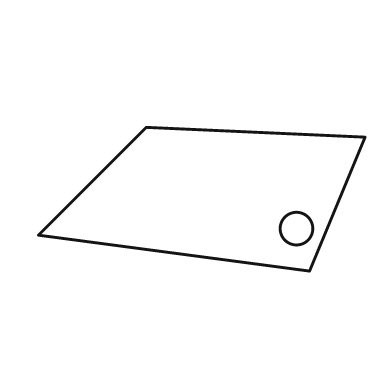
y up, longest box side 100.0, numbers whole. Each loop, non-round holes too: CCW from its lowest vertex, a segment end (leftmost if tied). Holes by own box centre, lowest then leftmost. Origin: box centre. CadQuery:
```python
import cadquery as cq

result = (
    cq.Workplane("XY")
    .moveTo(33.0, -22.0)
    .lineTo(50.0, 19.0)
    .lineTo(-17.0, 22.0)
    .lineTo(-50.0, -11.0)
    .close()
    .moveTo(29.0, -9.0)
    .circle(5.0)
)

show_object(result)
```